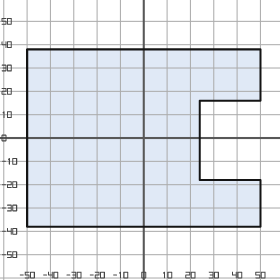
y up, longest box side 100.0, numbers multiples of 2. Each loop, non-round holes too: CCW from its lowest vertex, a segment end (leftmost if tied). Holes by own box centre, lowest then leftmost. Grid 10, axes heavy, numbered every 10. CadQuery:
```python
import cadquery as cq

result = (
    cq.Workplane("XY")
    .moveTo(-50.0, -38.0)
    .lineTo(50.0, -38.0)
    .lineTo(50.0, -18.0)
    .lineTo(24.0, -18.0)
    .lineTo(24.0, 16.0)
    .lineTo(50.0, 16.0)
    .lineTo(50.0, 38.0)
    .lineTo(-50.0, 38.0)
    .close()
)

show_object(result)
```